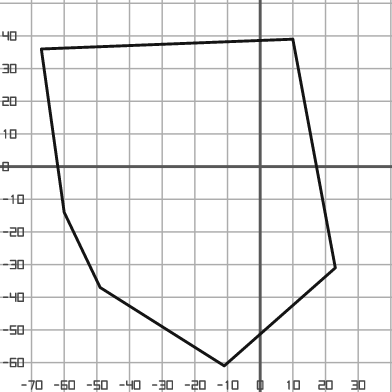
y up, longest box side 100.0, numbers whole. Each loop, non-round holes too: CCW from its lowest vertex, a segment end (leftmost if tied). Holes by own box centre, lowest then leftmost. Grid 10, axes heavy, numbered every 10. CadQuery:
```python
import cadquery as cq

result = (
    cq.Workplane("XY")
    .moveTo(-11.0, -61.0)
    .lineTo(23.0, -31.0)
    .lineTo(10.0, 39.0)
    .lineTo(-67.0, 36.0)
    .lineTo(-60.0, -14.0)
    .lineTo(-49.0, -37.0)
    .close()
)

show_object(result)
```